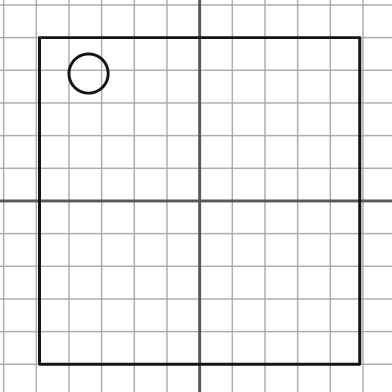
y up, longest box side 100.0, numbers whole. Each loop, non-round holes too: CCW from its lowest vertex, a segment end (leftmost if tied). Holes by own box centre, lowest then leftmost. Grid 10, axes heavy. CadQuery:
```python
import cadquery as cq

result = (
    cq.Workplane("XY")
    .moveTo(-49.0, -50.0)
    .lineTo(49.0, -50.0)
    .lineTo(49.0, 50.0)
    .lineTo(-49.0, 50.0)
    .close()
    .moveTo(-34.0, 39.0)
    .circle(6.0)
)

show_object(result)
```